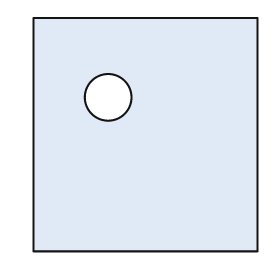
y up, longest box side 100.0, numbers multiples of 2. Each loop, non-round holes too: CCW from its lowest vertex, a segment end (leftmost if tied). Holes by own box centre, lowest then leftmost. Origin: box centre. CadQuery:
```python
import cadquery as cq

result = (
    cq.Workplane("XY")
    .moveTo(-48.0, -50.0)
    .lineTo(48.0, -50.0)
    .lineTo(48.0, 50.0)
    .lineTo(-48.0, 50.0)
    .close()
    .moveTo(-16.0, 16.0)
    .circle(10.0)
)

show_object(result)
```